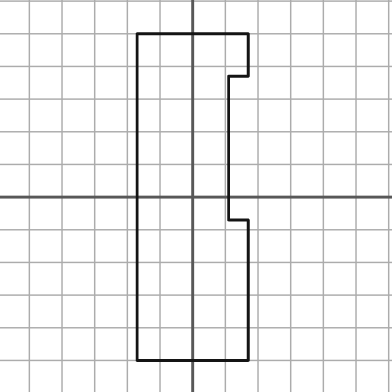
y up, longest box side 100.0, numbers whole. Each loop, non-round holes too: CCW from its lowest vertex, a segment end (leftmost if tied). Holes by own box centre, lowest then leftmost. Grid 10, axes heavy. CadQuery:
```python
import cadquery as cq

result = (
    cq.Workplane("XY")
    .moveTo(-17.0, -50.0)
    .lineTo(17.0, -50.0)
    .lineTo(17.0, -7.0)
    .lineTo(11.0, -7.0)
    .lineTo(11.0, 37.0)
    .lineTo(17.0, 37.0)
    .lineTo(17.0, 50.0)
    .lineTo(-17.0, 50.0)
    .close()
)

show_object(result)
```